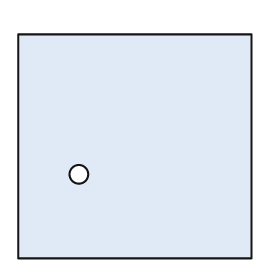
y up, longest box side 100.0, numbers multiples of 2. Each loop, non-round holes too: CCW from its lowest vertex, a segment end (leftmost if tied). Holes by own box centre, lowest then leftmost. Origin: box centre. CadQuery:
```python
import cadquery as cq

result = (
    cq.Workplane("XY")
    .moveTo(-50.0, -48.0)
    .lineTo(50.0, -48.0)
    .lineTo(50.0, 48.0)
    .lineTo(-50.0, 48.0)
    .close()
    .moveTo(-24.0, -12.0)
    .circle(4.0)
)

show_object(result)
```